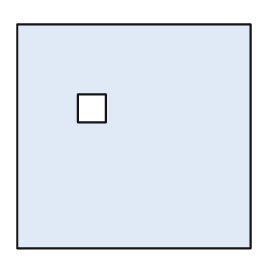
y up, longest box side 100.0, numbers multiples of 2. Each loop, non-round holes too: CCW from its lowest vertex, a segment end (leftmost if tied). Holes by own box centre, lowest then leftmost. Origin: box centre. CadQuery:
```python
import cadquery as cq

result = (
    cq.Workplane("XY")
    .moveTo(-50.0, -48.0)
    .lineTo(50.0, -48.0)
    .lineTo(50.0, 48.0)
    .lineTo(-50.0, 48.0)
    .close()
    .moveTo(-24.0, 6.0)
    .lineTo(-12.0, 6.0)
    .lineTo(-12.0, 18.0)
    .lineTo(-24.0, 18.0)
    .close()
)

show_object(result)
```